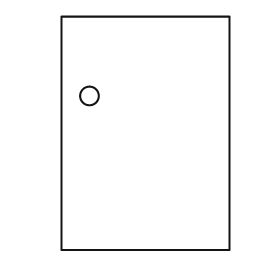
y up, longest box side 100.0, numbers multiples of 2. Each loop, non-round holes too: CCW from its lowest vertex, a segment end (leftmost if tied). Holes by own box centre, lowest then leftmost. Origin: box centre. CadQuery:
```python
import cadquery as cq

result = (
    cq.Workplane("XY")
    .moveTo(-36.0, -50.0)
    .lineTo(36.0, -50.0)
    .lineTo(36.0, 50.0)
    .lineTo(-36.0, 50.0)
    .close()
    .moveTo(-24.0, 16.0)
    .circle(4.0)
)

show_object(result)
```